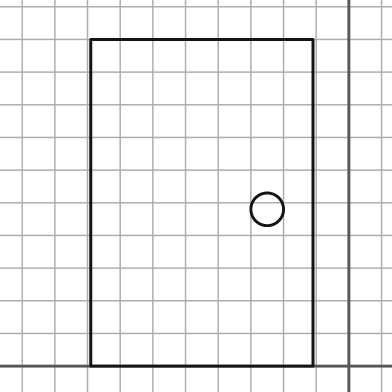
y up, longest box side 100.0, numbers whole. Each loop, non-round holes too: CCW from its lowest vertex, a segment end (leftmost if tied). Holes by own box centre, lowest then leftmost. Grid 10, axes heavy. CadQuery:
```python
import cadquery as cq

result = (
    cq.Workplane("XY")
    .moveTo(-79.0, 0.0)
    .lineTo(-11.0, 0.0)
    .lineTo(-11.0, 100.0)
    .lineTo(-79.0, 100.0)
    .close()
    .moveTo(-25.0, 48.0)
    .circle(5.0)
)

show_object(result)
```